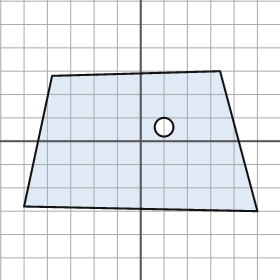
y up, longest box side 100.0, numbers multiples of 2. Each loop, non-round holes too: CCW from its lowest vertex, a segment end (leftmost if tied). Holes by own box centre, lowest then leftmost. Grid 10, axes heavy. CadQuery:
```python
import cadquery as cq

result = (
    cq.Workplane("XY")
    .moveTo(50.0, -30.0)
    .lineTo(34.0, 30.0)
    .lineTo(-38.0, 28.0)
    .lineTo(-50.0, -28.0)
    .close()
    .moveTo(10.0, 6.0)
    .circle(4.0)
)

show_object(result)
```